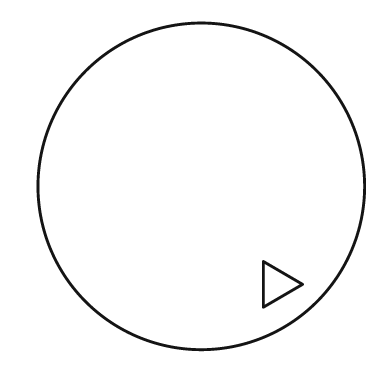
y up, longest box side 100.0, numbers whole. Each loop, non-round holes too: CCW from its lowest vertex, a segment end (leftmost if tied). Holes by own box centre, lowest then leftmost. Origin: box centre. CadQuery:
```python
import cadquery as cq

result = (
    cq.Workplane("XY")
    .moveTo(0.0, 0.0)
    .circle(50.0)
    .moveTo(19.0, -37.0)
    .lineTo(31.0, -30.0)
    .lineTo(19.0, -23.0)
    .close()
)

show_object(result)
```